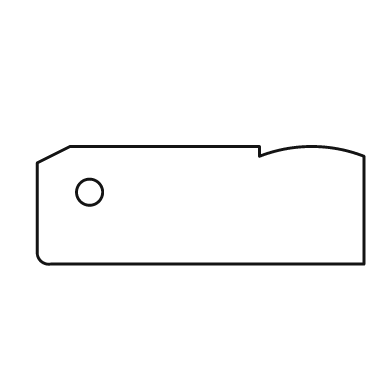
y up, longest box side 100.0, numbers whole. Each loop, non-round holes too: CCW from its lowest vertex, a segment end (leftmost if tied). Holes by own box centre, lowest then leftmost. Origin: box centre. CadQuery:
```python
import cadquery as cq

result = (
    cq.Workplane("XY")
    .moveTo(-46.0, -18.0)
    .lineTo(50.0, -18.0)
    .lineTo(50.0, 15.0)
    .threePointArc((34.0, 18.0), (18.0, 15.0))
    .lineTo(18.0, 18.0)
    .lineTo(-40.0, 18.0)
    .lineTo(-50.0, 13.0)
    .lineTo(-50.0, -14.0)
    .threePointArc((-49.0, -17.0), (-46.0, -18.0))
    .close()
    .moveTo(-34.0, 4.0)
    .circle(4.0)
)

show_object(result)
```